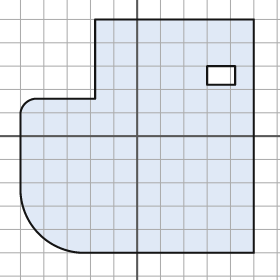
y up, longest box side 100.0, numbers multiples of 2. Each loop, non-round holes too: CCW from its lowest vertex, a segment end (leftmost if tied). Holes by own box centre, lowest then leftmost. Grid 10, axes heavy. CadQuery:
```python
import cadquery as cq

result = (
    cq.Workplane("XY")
    .moveTo(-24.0, -50.0)
    .lineTo(50.0, -50.0)
    .lineTo(50.0, 50.0)
    .lineTo(-18.0, 50.0)
    .lineTo(-18.0, 16.0)
    .lineTo(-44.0, 16.0)
    .threePointArc((-48.0, 14.0), (-50.0, 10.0))
    .lineTo(-50.0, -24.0)
    .threePointArc((-42.0, -42.0), (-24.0, -50.0))
    .close()
    .moveTo(30.0, 22.0)
    .lineTo(42.0, 22.0)
    .lineTo(42.0, 30.0)
    .lineTo(30.0, 30.0)
    .close()
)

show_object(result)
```